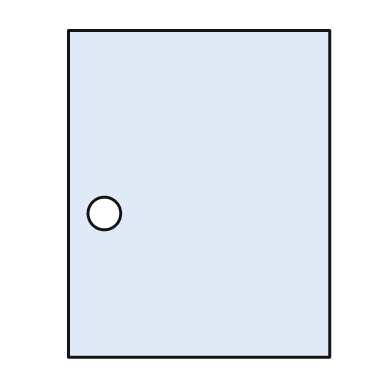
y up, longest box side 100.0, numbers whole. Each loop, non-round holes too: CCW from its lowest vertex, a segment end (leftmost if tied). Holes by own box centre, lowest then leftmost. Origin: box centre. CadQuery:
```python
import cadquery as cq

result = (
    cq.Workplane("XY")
    .moveTo(-40.0, -50.0)
    .lineTo(40.0, -50.0)
    .lineTo(40.0, 50.0)
    .lineTo(-40.0, 50.0)
    .close()
    .moveTo(-29.0, -6.0)
    .circle(5.0)
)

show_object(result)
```